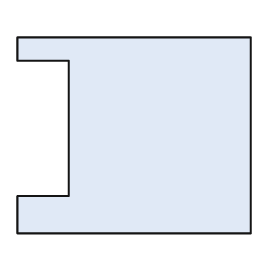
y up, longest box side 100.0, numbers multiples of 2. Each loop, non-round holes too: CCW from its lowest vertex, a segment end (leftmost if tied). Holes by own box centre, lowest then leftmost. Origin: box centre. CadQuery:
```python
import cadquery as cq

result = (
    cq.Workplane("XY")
    .moveTo(-50.0, -42.0)
    .lineTo(50.0, -42.0)
    .lineTo(50.0, 42.0)
    .lineTo(-50.0, 42.0)
    .lineTo(-50.0, 32.0)
    .lineTo(-28.0, 32.0)
    .lineTo(-28.0, -26.0)
    .lineTo(-50.0, -26.0)
    .close()
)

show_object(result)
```